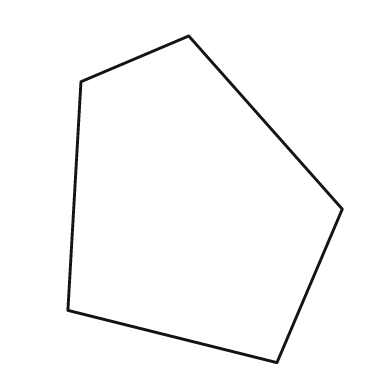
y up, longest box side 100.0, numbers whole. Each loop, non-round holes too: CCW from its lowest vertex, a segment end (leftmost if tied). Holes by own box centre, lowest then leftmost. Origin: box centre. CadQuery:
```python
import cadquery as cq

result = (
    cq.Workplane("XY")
    .moveTo(22.0, -50.0)
    .lineTo(42.0, -3.0)
    .lineTo(-5.0, 50.0)
    .lineTo(-38.0, 36.0)
    .lineTo(-42.0, -34.0)
    .close()
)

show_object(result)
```